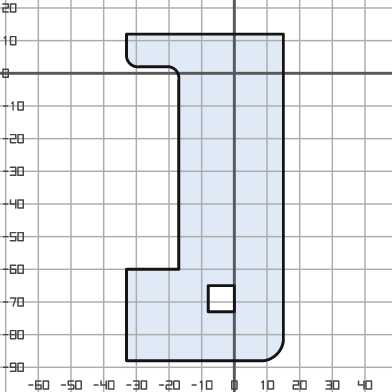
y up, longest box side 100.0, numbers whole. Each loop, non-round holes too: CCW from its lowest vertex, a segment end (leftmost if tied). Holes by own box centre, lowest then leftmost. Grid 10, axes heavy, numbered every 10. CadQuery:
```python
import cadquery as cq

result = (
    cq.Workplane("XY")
    .moveTo(-33.0, -88.0)
    .lineTo(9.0, -88.0)
    .threePointArc((13.0, -86.0), (15.0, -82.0))
    .lineTo(15.0, 12.0)
    .lineTo(-33.0, 12.0)
    .lineTo(-33.0, 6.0)
    .threePointArc((-32.0, 3.0), (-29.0, 2.0))
    .lineTo(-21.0, 2.0)
    .threePointArc((-18.0, 1.0), (-17.0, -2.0))
    .lineTo(-17.0, -60.0)
    .lineTo(-33.0, -60.0)
    .close()
    .moveTo(-8.0, -73.0)
    .lineTo(0.0, -73.0)
    .lineTo(0.0, -65.0)
    .lineTo(-8.0, -65.0)
    .close()
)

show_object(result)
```